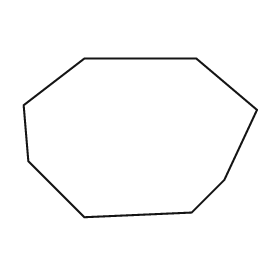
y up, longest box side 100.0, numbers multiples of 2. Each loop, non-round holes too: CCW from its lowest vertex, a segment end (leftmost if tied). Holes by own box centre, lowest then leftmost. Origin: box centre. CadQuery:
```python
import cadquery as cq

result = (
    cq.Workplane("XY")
    .moveTo(-24.0, -34.0)
    .lineTo(22.0, -32.0)
    .lineTo(36.0, -18.0)
    .lineTo(50.0, 12.0)
    .lineTo(24.0, 34.0)
    .lineTo(-24.0, 34.0)
    .lineTo(-50.0, 14.0)
    .lineTo(-48.0, -10.0)
    .close()
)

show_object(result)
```